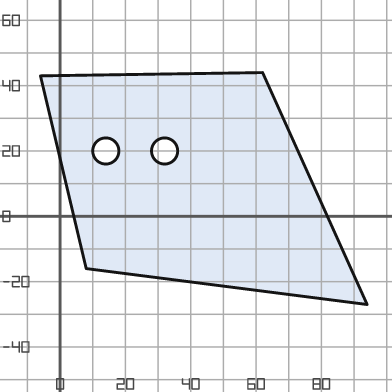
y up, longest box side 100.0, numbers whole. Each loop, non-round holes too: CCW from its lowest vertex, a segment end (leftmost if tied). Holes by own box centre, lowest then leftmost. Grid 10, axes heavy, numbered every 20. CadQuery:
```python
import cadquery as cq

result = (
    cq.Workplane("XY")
    .moveTo(94.0, -27.0)
    .lineTo(62.0, 44.0)
    .lineTo(-6.0, 43.0)
    .lineTo(8.0, -16.0)
    .close()
    .moveTo(14.0, 20.0)
    .circle(4.0)
    .moveTo(32.0, 20.0)
    .circle(4.0)
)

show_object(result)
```